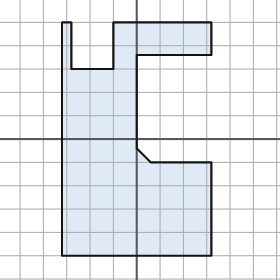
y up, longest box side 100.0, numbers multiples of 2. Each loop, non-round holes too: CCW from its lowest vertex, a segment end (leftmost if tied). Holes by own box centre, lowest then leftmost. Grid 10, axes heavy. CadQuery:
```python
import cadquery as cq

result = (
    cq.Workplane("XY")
    .moveTo(-32.0, -50.0)
    .lineTo(32.0, -50.0)
    .lineTo(32.0, -10.0)
    .lineTo(6.0, -10.0)
    .lineTo(0.0, -4.0)
    .lineTo(0.0, 36.0)
    .lineTo(32.0, 36.0)
    .lineTo(32.0, 50.0)
    .lineTo(-10.0, 50.0)
    .lineTo(-10.0, 30.0)
    .lineTo(-28.0, 30.0)
    .lineTo(-28.0, 50.0)
    .lineTo(-32.0, 50.0)
    .close()
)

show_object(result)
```